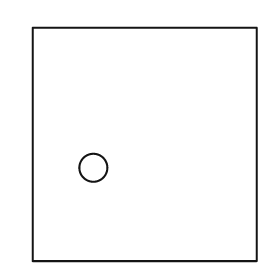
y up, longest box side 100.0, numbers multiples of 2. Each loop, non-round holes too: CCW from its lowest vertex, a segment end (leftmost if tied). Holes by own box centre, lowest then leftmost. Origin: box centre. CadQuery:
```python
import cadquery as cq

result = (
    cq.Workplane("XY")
    .moveTo(-48.0, -50.0)
    .lineTo(48.0, -50.0)
    .lineTo(48.0, 50.0)
    .lineTo(-48.0, 50.0)
    .close()
    .moveTo(-22.0, -10.0)
    .circle(6.0)
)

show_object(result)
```